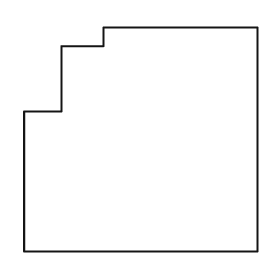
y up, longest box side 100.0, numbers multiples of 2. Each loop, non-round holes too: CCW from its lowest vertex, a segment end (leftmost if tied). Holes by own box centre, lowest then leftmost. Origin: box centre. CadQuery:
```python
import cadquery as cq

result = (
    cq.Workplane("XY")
    .moveTo(-50.0, -48.0)
    .lineTo(50.0, -48.0)
    .lineTo(50.0, 48.0)
    .lineTo(-16.0, 48.0)
    .lineTo(-16.0, 40.0)
    .lineTo(-34.0, 40.0)
    .lineTo(-34.0, 12.0)
    .lineTo(-50.0, 12.0)
    .close()
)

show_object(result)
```